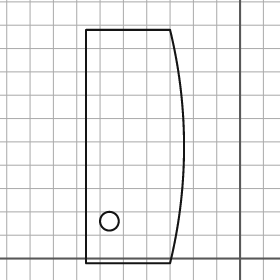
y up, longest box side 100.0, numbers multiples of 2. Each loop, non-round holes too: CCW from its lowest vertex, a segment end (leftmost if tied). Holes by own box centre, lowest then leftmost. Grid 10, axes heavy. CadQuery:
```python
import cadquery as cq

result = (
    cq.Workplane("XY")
    .moveTo(-66.0, -2.0)
    .lineTo(-30.0, -2.0)
    .threePointArc((-24.0, 48.0), (-30.0, 98.0))
    .lineTo(-66.0, 98.0)
    .close()
    .moveTo(-56.0, 16.0)
    .circle(4.0)
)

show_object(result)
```